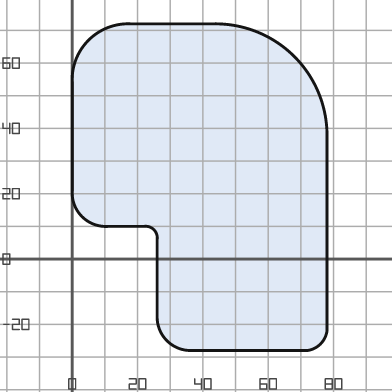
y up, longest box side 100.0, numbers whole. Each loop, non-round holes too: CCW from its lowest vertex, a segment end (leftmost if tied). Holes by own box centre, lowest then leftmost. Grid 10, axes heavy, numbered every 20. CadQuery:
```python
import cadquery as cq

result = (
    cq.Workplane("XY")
    .moveTo(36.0, -28.0)
    .lineTo(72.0, -28.0)
    .threePointArc((76.0, -26.0), (78.0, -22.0))
    .lineTo(78.0, 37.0)
    .threePointArc((68.0, 62.0), (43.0, 72.0))
    .lineTo(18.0, 72.0)
    .threePointArc((5.0, 67.0), (0.0, 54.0))
    .lineTo(0.0, 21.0)
    .threePointArc((3.0, 13.0), (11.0, 10.0))
    .lineTo(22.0, 10.0)
    .threePointArc((25.0, 9.0), (26.0, 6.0))
    .lineTo(26.0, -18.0)
    .threePointArc((29.0, -25.0), (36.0, -28.0))
    .close()
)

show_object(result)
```